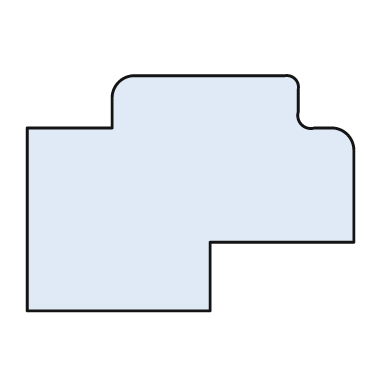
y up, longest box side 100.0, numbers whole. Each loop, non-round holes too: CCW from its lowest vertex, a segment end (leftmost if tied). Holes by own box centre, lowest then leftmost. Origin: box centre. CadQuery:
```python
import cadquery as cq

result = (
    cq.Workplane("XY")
    .moveTo(-50.0, -36.0)
    .lineTo(6.0, -36.0)
    .lineTo(6.0, -15.0)
    .lineTo(50.0, -15.0)
    .lineTo(50.0, 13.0)
    .threePointArc((48.0, 18.0), (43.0, 20.0))
    .lineTo(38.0, 20.0)
    .threePointArc((34.0, 21.0), (33.0, 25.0))
    .lineTo(33.0, 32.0)
    .threePointArc((32.0, 35.0), (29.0, 36.0))
    .lineTo(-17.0, 36.0)
    .threePointArc((-22.0, 34.0), (-24.0, 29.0))
    .lineTo(-24.0, 20.0)
    .lineTo(-50.0, 20.0)
    .close()
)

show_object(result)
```